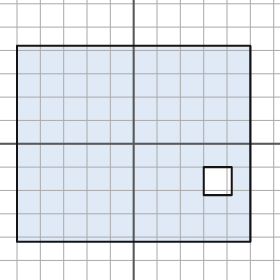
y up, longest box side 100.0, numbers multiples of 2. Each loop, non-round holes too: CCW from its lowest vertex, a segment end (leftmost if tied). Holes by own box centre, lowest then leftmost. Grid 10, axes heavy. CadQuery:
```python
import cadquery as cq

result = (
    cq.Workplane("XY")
    .moveTo(-50.0, -42.0)
    .lineTo(50.0, -42.0)
    .lineTo(50.0, 42.0)
    .lineTo(-50.0, 42.0)
    .close()
    .moveTo(30.0, -22.0)
    .lineTo(42.0, -22.0)
    .lineTo(42.0, -10.0)
    .lineTo(30.0, -10.0)
    .close()
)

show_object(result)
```